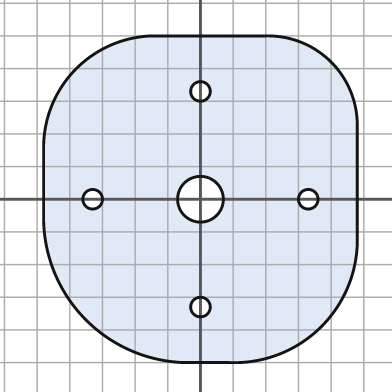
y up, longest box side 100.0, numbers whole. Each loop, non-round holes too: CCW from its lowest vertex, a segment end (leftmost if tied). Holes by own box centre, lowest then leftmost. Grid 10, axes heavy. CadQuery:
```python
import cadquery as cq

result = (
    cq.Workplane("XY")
    .moveTo(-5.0, -50.0)
    .lineTo(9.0, -50.0)
    .threePointArc((37.0, -39.0), (48.0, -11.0))
    .lineTo(48.0, 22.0)
    .threePointArc((40.0, 42.0), (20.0, 50.0))
    .lineTo(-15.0, 50.0)
    .threePointArc((-38.0, 40.0), (-48.0, 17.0))
    .lineTo(-48.0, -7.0)
    .threePointArc((-35.0, -37.0), (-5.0, -50.0))
    .close()
    .moveTo(0.0, -33.0)
    .circle(3.0)
    .moveTo(-33.0, 0.0)
    .circle(3.0)
    .moveTo(0.0, 0.0)
    .circle(7.0)
    .moveTo(33.0, 0.0)
    .circle(3.0)
    .moveTo(0.0, 33.0)
    .circle(3.0)
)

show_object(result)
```